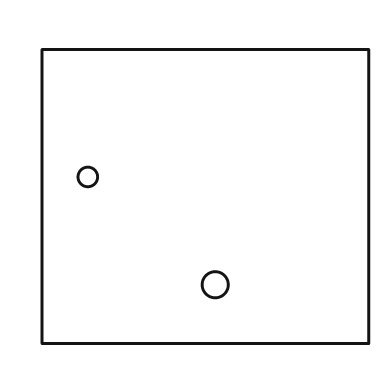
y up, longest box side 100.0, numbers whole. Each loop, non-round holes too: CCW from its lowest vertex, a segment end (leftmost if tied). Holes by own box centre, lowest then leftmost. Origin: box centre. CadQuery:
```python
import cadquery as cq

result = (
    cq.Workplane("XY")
    .moveTo(-50.0, -45.0)
    .lineTo(50.0, -45.0)
    .lineTo(50.0, 45.0)
    .lineTo(-50.0, 45.0)
    .close()
    .moveTo(3.0, -27.0)
    .circle(4.0)
    .moveTo(-36.0, 6.0)
    .circle(3.0)
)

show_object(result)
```